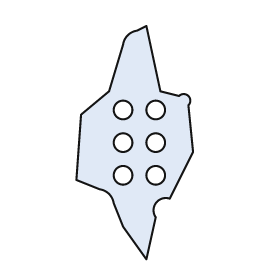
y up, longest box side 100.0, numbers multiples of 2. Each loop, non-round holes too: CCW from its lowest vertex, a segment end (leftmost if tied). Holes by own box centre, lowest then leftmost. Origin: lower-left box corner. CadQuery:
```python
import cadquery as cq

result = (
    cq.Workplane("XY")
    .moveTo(30.0, 0.0)
    .lineTo(34.0, 18.0)
    .threePointArc((34.0, 24.0), (40.0, 26.0))
    .lineTo(50.0, 46.0)
    .lineTo(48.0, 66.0)
    .threePointArc((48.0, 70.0), (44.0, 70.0))
    .lineTo(36.0, 72.0)
    .lineTo(30.0, 100.0)
    .lineTo(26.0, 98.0)
    .threePointArc((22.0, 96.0), (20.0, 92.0))
    .lineTo(14.0, 72.0)
    .lineTo(2.0, 62.0)
    .lineTo(0.0, 34.0)
    .lineTo(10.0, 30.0)
    .threePointArc((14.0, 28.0), (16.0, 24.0))
    .lineTo(20.0, 14.0)
    .close()
    .moveTo(20.0, 36.0)
    .circle(4.0)
    .moveTo(34.0, 36.0)
    .circle(4.0)
    .moveTo(20.0, 50.0)
    .circle(4.0)
    .moveTo(34.0, 50.0)
    .circle(4.0)
    .moveTo(20.0, 64.0)
    .circle(4.0)
    .moveTo(34.0, 64.0)
    .circle(4.0)
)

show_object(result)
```